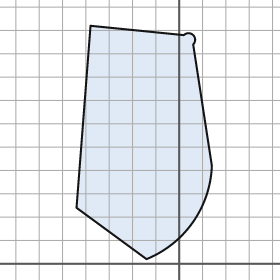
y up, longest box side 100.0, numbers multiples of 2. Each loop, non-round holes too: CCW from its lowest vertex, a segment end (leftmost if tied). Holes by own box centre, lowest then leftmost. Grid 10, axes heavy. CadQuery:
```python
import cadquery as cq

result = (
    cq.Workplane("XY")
    .moveTo(-14.0, 2.0)
    .threePointArc((6.0, 18.0), (14.0, 42.0))
    .lineTo(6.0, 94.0)
    .threePointArc((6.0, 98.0), (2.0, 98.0))
    .lineTo(-38.0, 102.0)
    .lineTo(-44.0, 24.0)
    .close()
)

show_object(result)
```